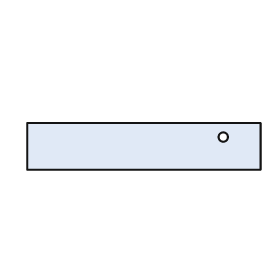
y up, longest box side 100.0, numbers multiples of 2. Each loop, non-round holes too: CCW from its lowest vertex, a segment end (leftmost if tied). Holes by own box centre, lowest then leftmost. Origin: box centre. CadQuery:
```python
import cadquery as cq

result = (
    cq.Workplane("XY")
    .moveTo(-50.0, -10.0)
    .lineTo(50.0, -10.0)
    .lineTo(50.0, 10.0)
    .lineTo(-50.0, 10.0)
    .close()
    .moveTo(34.0, 4.0)
    .circle(2.0)
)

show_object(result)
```